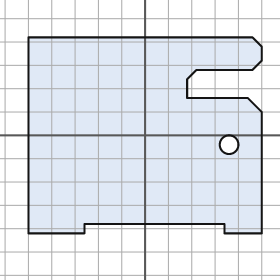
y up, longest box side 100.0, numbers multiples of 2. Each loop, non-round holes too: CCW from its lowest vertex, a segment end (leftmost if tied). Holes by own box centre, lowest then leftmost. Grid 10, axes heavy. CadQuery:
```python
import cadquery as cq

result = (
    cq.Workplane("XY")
    .moveTo(-50.0, -42.0)
    .lineTo(-26.0, -42.0)
    .lineTo(-26.0, -38.0)
    .lineTo(34.0, -38.0)
    .lineTo(34.0, -42.0)
    .lineTo(50.0, -42.0)
    .lineTo(50.0, 10.0)
    .lineTo(44.0, 16.0)
    .lineTo(18.0, 16.0)
    .lineTo(18.0, 24.0)
    .lineTo(22.0, 28.0)
    .lineTo(46.0, 28.0)
    .lineTo(50.0, 32.0)
    .lineTo(50.0, 38.0)
    .lineTo(46.0, 42.0)
    .lineTo(-50.0, 42.0)
    .close()
    .moveTo(36.0, -4.0)
    .circle(4.0)
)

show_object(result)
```